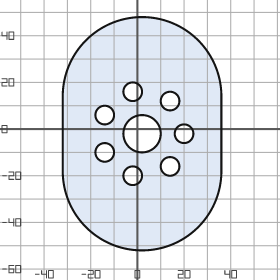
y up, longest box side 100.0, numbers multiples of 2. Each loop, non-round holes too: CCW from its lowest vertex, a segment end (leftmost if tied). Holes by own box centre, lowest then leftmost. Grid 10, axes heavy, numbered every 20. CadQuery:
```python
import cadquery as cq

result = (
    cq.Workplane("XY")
    .moveTo(-32.0, -18.0)
    .threePointArc((2.0, -52.0), (36.0, -18.0))
    .lineTo(36.0, 14.0)
    .threePointArc((2.0, 48.0), (-32.0, 14.0))
    .close()
    .moveTo(-2.0, -20.0)
    .circle(4.0)
    .moveTo(14.0, -16.0)
    .circle(4.0)
    .moveTo(-14.0, -10.0)
    .circle(4.0)
    .moveTo(2.0, -2.0)
    .circle(8.0)
    .moveTo(20.0, -2.0)
    .circle(4.0)
    .moveTo(-14.0, 6.0)
    .circle(4.0)
    .moveTo(14.0, 12.0)
    .circle(4.0)
    .moveTo(-2.0, 16.0)
    .circle(4.0)
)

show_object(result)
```